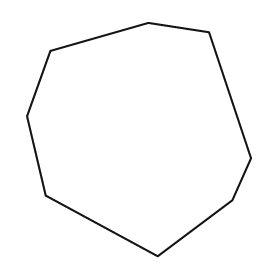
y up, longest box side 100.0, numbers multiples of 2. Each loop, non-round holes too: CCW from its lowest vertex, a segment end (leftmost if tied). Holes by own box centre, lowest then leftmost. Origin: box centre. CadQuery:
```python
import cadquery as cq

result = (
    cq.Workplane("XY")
    .moveTo(8.0, -50.0)
    .lineTo(40.0, -26.0)
    .lineTo(48.0, -8.0)
    .lineTo(30.0, 46.0)
    .lineTo(4.0, 50.0)
    .lineTo(-38.0, 38.0)
    .lineTo(-48.0, 10.0)
    .lineTo(-40.0, -24.0)
    .close()
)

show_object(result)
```